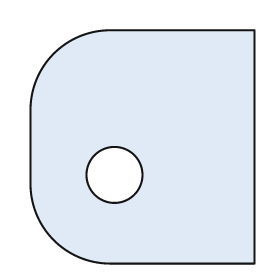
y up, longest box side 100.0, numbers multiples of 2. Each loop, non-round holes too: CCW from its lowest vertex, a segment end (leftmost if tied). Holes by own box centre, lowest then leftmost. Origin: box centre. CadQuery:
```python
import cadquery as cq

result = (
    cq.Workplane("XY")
    .moveTo(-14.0, -50.0)
    .lineTo(48.0, -50.0)
    .lineTo(48.0, 50.0)
    .lineTo(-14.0, 50.0)
    .threePointArc((-38.0, 40.0), (-48.0, 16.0))
    .lineTo(-48.0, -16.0)
    .threePointArc((-38.0, -40.0), (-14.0, -50.0))
    .close()
    .moveTo(-12.0, -12.0)
    .circle(12.0)
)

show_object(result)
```